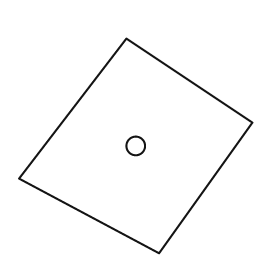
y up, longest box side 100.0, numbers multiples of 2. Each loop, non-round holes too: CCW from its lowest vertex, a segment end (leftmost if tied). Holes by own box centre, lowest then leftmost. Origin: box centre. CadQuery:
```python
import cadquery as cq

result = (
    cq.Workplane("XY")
    .moveTo(10.0, -46.0)
    .lineTo(50.0, 10.0)
    .lineTo(-4.0, 46.0)
    .lineTo(-50.0, -14.0)
    .close()
    .moveTo(0.0, 0.0)
    .circle(4.0)
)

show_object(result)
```